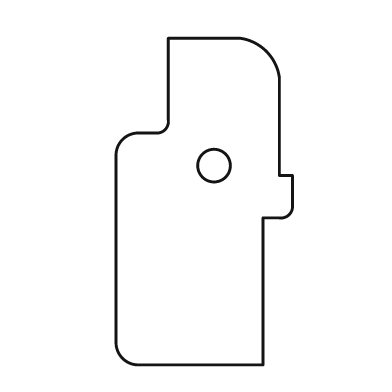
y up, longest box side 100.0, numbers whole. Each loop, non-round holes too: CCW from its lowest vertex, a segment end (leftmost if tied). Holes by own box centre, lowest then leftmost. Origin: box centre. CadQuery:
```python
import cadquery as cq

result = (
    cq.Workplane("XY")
    .moveTo(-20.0, -50.0)
    .lineTo(18.0, -50.0)
    .lineTo(18.0, -5.0)
    .lineTo(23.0, -5.0)
    .threePointArc((26.0, -4.0), (27.0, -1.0))
    .lineTo(27.0, 8.0)
    .lineTo(23.0, 8.0)
    .lineTo(23.0, 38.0)
    .threePointArc((19.0, 46.0), (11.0, 50.0))
    .lineTo(-11.0, 50.0)
    .lineTo(-11.0, 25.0)
    .threePointArc((-12.0, 22.0), (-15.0, 21.0))
    .lineTo(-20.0, 21.0)
    .threePointArc((-25.0, 19.0), (-27.0, 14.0))
    .lineTo(-27.0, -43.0)
    .threePointArc((-25.0, -48.0), (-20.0, -50.0))
    .close()
    .moveTo(3.0, 11.0)
    .circle(5.0)
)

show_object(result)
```